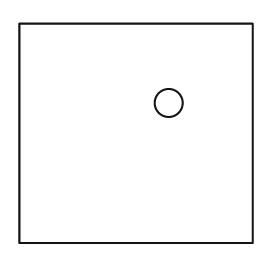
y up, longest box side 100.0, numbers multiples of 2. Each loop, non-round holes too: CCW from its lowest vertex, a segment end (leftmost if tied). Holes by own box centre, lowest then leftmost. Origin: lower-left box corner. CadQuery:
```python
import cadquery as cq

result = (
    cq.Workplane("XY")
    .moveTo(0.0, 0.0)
    .lineTo(100.0, 0.0)
    .lineTo(100.0, 94.0)
    .lineTo(0.0, 94.0)
    .close()
    .moveTo(64.0, 60.0)
    .circle(6.0)
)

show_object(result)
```